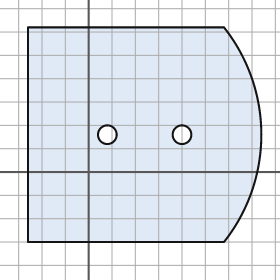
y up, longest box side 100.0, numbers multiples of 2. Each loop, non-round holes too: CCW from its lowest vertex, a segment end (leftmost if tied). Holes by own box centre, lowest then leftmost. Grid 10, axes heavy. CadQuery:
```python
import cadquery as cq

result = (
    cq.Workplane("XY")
    .moveTo(-26.0, -30.0)
    .lineTo(58.0, -30.0)
    .threePointArc((74.0, 16.0), (58.0, 62.0))
    .lineTo(-26.0, 62.0)
    .close()
    .moveTo(8.0, 16.0)
    .circle(4.0)
    .moveTo(40.0, 16.0)
    .circle(4.0)
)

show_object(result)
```